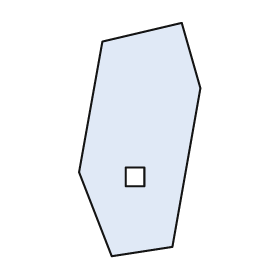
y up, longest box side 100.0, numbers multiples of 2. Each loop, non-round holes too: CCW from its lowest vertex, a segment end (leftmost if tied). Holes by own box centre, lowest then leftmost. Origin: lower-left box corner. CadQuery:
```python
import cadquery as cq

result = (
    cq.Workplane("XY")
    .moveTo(14.0, 0.0)
    .lineTo(40.0, 4.0)
    .lineTo(52.0, 72.0)
    .lineTo(44.0, 100.0)
    .lineTo(10.0, 92.0)
    .lineTo(0.0, 36.0)
    .close()
    .moveTo(20.0, 30.0)
    .lineTo(28.0, 30.0)
    .lineTo(28.0, 38.0)
    .lineTo(20.0, 38.0)
    .close()
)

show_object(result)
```